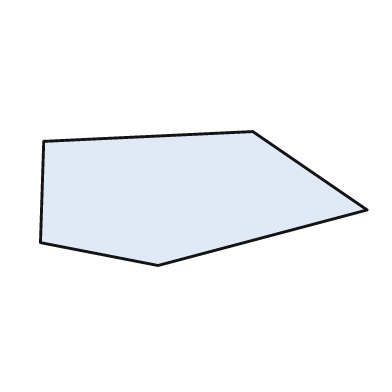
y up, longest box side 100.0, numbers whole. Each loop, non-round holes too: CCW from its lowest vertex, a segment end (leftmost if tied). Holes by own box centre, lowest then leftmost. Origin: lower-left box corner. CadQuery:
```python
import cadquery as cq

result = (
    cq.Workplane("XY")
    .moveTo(36.0, 0.0)
    .lineTo(100.0, 17.0)
    .lineTo(65.0, 41.0)
    .lineTo(1.0, 38.0)
    .lineTo(0.0, 7.0)
    .close()
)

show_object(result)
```